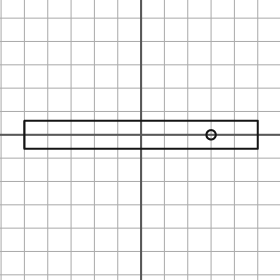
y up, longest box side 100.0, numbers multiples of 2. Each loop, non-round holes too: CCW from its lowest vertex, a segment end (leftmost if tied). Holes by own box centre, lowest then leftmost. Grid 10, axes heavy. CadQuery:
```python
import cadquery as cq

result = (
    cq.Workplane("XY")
    .moveTo(-50.0, -6.0)
    .lineTo(50.0, -6.0)
    .lineTo(50.0, 6.0)
    .lineTo(-50.0, 6.0)
    .close()
    .moveTo(30.0, 0.0)
    .circle(2.0)
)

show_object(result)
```